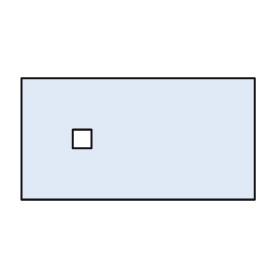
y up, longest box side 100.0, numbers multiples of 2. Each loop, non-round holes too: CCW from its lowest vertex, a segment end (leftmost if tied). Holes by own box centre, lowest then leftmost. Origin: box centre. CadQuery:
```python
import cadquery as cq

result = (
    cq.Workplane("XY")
    .moveTo(-50.0, -26.0)
    .lineTo(50.0, -26.0)
    .lineTo(50.0, 26.0)
    .lineTo(-50.0, 26.0)
    .close()
    .moveTo(-28.0, -4.0)
    .lineTo(-20.0, -4.0)
    .lineTo(-20.0, 4.0)
    .lineTo(-28.0, 4.0)
    .close()
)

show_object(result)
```